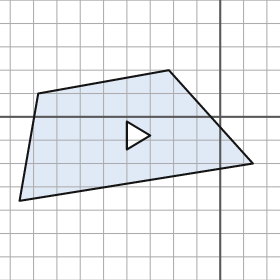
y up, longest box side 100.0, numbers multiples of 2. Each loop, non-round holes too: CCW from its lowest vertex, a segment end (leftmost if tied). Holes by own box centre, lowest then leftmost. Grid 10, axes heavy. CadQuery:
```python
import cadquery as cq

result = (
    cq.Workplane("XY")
    .moveTo(-86.0, -36.0)
    .lineTo(14.0, -20.0)
    .lineTo(-22.0, 20.0)
    .lineTo(-78.0, 10.0)
    .close()
    .moveTo(-40.0, -14.0)
    .lineTo(-30.0, -8.0)
    .lineTo(-40.0, -2.0)
    .close()
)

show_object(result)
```